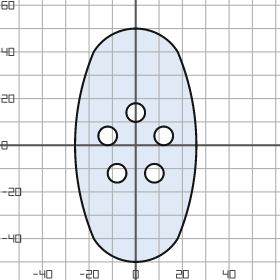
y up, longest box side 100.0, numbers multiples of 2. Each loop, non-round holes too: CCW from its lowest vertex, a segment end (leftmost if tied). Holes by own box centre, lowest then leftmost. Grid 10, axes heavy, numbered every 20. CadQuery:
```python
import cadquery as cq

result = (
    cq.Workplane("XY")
    .moveTo(-18.0, -40.0)
    .threePointArc((0.0, -50.0), (18.0, -40.0))
    .threePointArc((26.0, 0.0), (18.0, 40.0))
    .threePointArc((0.0, 50.0), (-18.0, 40.0))
    .threePointArc((-26.0, 0.0), (-18.0, -40.0))
    .close()
    .moveTo(-8.0, -12.0)
    .circle(4.0)
    .moveTo(8.0, -12.0)
    .circle(4.0)
    .moveTo(-12.0, 4.0)
    .circle(4.0)
    .moveTo(12.0, 4.0)
    .circle(4.0)
    .moveTo(0.0, 14.0)
    .circle(4.0)
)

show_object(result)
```